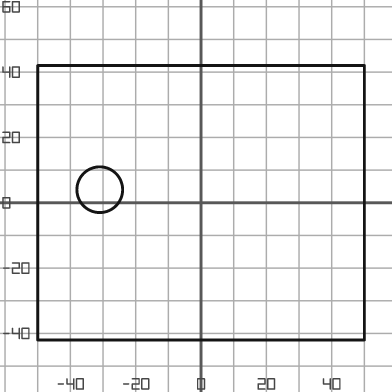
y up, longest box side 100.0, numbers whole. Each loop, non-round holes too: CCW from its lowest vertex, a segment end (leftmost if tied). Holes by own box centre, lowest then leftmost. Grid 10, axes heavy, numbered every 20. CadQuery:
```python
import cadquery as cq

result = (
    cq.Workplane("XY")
    .moveTo(-50.0, -42.0)
    .lineTo(50.0, -42.0)
    .lineTo(50.0, 42.0)
    .lineTo(-50.0, 42.0)
    .close()
    .moveTo(-31.0, 4.0)
    .circle(7.0)
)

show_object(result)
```